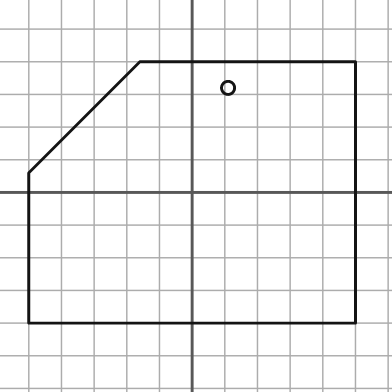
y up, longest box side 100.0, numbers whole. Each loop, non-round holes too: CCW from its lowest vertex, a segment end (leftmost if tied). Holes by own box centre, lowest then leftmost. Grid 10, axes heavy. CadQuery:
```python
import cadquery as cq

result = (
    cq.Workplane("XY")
    .moveTo(-50.0, -40.0)
    .lineTo(50.0, -40.0)
    .lineTo(50.0, 40.0)
    .lineTo(-16.0, 40.0)
    .lineTo(-50.0, 6.0)
    .close()
    .moveTo(11.0, 32.0)
    .circle(2.0)
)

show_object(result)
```